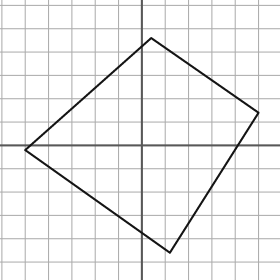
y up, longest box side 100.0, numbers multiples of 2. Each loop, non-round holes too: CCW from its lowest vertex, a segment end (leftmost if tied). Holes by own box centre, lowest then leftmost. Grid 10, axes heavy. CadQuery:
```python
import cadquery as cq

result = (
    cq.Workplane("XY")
    .moveTo(12.0, -46.0)
    .lineTo(50.0, 14.0)
    .lineTo(4.0, 46.0)
    .lineTo(-50.0, -2.0)
    .close()
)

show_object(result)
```